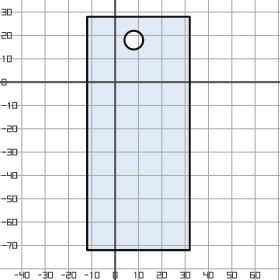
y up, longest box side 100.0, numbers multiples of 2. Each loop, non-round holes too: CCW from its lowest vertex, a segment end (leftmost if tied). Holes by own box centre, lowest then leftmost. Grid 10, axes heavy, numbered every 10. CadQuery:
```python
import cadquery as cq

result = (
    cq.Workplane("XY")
    .moveTo(-12.0, -72.0)
    .lineTo(32.0, -72.0)
    .lineTo(32.0, 28.0)
    .lineTo(-12.0, 28.0)
    .close()
    .moveTo(8.0, 18.0)
    .circle(4.0)
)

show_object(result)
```